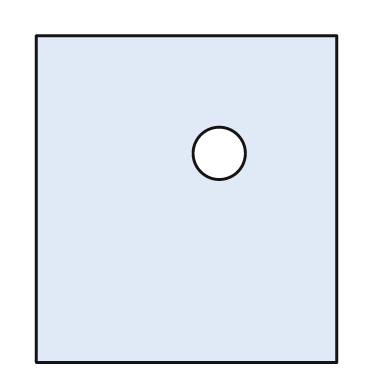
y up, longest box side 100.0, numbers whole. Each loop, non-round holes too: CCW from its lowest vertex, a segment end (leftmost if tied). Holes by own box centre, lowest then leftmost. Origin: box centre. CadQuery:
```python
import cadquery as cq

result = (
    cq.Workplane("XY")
    .moveTo(-46.0, -50.0)
    .lineTo(46.0, -50.0)
    .lineTo(46.0, 50.0)
    .lineTo(-46.0, 50.0)
    .close()
    .moveTo(10.0, 14.0)
    .circle(8.0)
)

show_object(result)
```